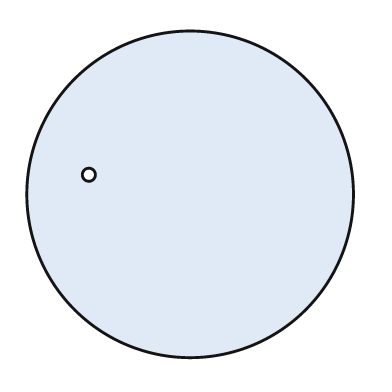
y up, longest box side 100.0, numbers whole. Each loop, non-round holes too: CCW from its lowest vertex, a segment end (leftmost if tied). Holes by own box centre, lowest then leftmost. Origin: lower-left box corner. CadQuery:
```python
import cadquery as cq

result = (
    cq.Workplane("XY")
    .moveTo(50.0, 50.0)
    .circle(50.0)
    .moveTo(19.0, 56.0)
    .circle(2.0)
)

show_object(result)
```